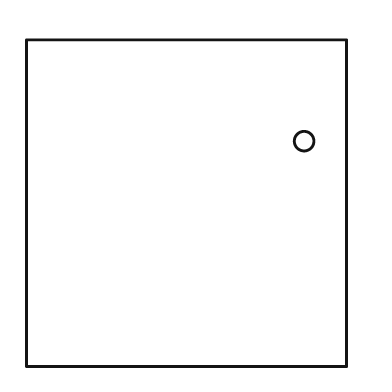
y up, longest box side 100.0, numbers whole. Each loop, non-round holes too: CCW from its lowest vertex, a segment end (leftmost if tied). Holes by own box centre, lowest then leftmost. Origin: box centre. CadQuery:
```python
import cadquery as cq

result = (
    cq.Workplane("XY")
    .moveTo(-49.0, -50.0)
    .lineTo(49.0, -50.0)
    .lineTo(49.0, 50.0)
    .lineTo(-49.0, 50.0)
    .close()
    .moveTo(36.0, 19.0)
    .circle(3.0)
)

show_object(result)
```